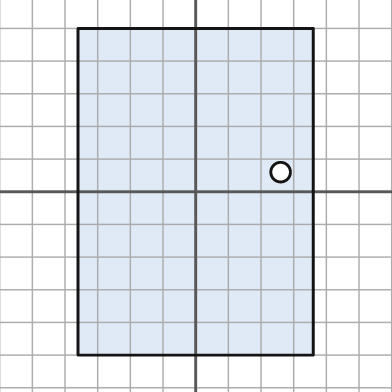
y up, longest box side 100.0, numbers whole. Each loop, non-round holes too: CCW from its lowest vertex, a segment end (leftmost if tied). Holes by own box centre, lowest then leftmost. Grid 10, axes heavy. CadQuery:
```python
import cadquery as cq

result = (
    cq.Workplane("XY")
    .moveTo(-36.0, -50.0)
    .lineTo(36.0, -50.0)
    .lineTo(36.0, 50.0)
    .lineTo(-36.0, 50.0)
    .close()
    .moveTo(26.0, 6.0)
    .circle(3.0)
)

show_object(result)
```